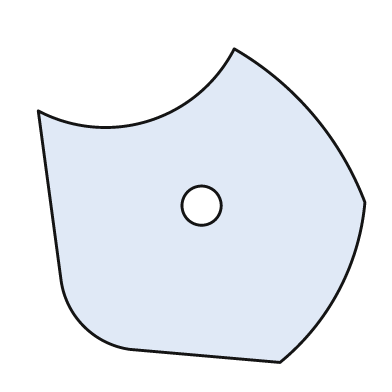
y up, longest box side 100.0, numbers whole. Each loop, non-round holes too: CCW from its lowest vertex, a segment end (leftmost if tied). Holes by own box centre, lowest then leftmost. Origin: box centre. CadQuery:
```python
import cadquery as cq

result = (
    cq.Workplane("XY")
    .moveTo(24.0, -48.0)
    .threePointArc((42.0, -26.0), (50.0, 1.0))
    .threePointArc((34.0, 28.0), (10.0, 48.0))
    .threePointArc((-16.0, 26.0), (-50.0, 29.0))
    .lineTo(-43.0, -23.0)
    .threePointArc((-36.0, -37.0), (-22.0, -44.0))
    .close()
    .moveTo(0.0, 0.0)
    .circle(6.0)
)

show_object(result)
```